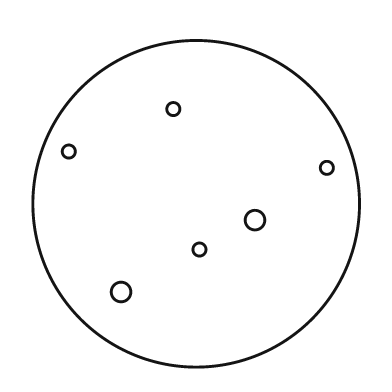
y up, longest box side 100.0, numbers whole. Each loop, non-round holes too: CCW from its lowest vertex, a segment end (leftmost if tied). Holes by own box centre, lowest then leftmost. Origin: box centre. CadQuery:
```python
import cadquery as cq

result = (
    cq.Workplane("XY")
    .moveTo(0.0, 0.0)
    .circle(50.0)
    .moveTo(-23.0, -27.0)
    .circle(3.0)
    .moveTo(1.0, -14.0)
    .circle(2.0)
    .moveTo(18.0, -5.0)
    .circle(3.0)
    .moveTo(40.0, 11.0)
    .circle(2.0)
    .moveTo(-39.0, 16.0)
    .circle(2.0)
    .moveTo(-7.0, 29.0)
    .circle(2.0)
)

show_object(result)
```